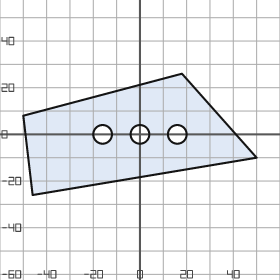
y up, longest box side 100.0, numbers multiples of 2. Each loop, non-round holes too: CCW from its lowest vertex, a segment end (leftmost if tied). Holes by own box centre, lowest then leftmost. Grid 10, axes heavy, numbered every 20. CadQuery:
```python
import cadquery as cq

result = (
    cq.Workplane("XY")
    .moveTo(-46.0, -26.0)
    .lineTo(50.0, -10.0)
    .lineTo(18.0, 26.0)
    .lineTo(-50.0, 8.0)
    .close()
    .moveTo(-16.0, 0.0)
    .circle(4.0)
    .moveTo(0.0, 0.0)
    .circle(4.0)
    .moveTo(16.0, 0.0)
    .circle(4.0)
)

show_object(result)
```